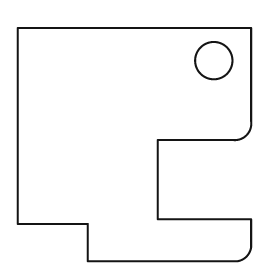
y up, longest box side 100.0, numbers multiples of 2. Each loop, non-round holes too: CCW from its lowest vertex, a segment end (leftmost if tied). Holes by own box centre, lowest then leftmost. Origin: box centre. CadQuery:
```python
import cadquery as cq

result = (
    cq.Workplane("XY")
    .moveTo(-20.0, -50.0)
    .lineTo(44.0, -50.0)
    .threePointArc((48.0, -48.0), (50.0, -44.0))
    .lineTo(50.0, -32.0)
    .lineTo(10.0, -32.0)
    .lineTo(10.0, 2.0)
    .lineTo(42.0, 2.0)
    .threePointArc((48.0, 4.0), (50.0, 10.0))
    .lineTo(50.0, 50.0)
    .lineTo(-50.0, 50.0)
    .lineTo(-50.0, -34.0)
    .lineTo(-20.0, -34.0)
    .close()
    .moveTo(34.0, 36.0)
    .circle(8.0)
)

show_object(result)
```